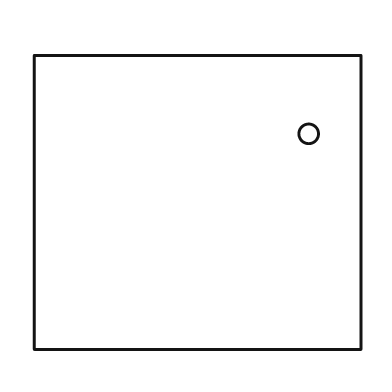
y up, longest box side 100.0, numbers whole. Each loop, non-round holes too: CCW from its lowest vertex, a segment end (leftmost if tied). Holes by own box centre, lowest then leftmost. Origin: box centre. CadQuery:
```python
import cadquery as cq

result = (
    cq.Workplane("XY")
    .moveTo(-50.0, -45.0)
    .lineTo(50.0, -45.0)
    .lineTo(50.0, 45.0)
    .lineTo(-50.0, 45.0)
    .close()
    .moveTo(34.0, 21.0)
    .circle(3.0)
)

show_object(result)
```